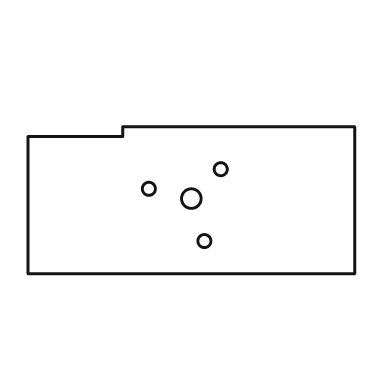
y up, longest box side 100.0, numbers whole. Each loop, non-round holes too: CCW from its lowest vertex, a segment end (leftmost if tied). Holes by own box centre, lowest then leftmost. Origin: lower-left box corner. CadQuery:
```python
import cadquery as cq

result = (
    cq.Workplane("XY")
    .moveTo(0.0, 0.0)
    .lineTo(100.0, 0.0)
    .lineTo(100.0, 45.0)
    .lineTo(29.0, 45.0)
    .lineTo(29.0, 42.0)
    .lineTo(0.0, 42.0)
    .close()
    .moveTo(54.0, 10.0)
    .circle(2.0)
    .moveTo(50.0, 23.0)
    .circle(3.0)
    .moveTo(37.0, 26.0)
    .circle(2.0)
    .moveTo(59.0, 32.0)
    .circle(2.0)
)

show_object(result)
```